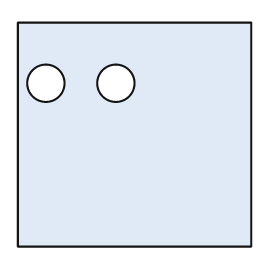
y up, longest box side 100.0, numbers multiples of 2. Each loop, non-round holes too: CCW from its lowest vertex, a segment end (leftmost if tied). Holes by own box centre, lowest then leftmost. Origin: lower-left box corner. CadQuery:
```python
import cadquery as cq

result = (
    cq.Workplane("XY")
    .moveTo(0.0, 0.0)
    .lineTo(100.0, 0.0)
    .lineTo(100.0, 96.0)
    .lineTo(0.0, 96.0)
    .close()
    .moveTo(12.0, 70.0)
    .circle(8.0)
    .moveTo(42.0, 70.0)
    .circle(8.0)
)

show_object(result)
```